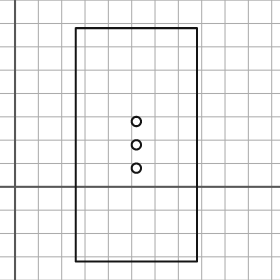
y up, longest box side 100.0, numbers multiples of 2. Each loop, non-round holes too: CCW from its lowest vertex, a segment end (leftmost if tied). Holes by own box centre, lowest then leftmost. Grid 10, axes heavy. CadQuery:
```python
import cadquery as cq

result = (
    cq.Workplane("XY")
    .moveTo(26.0, -32.0)
    .lineTo(78.0, -32.0)
    .lineTo(78.0, 68.0)
    .lineTo(26.0, 68.0)
    .close()
    .moveTo(52.0, 8.0)
    .circle(2.0)
    .moveTo(52.0, 18.0)
    .circle(2.0)
    .moveTo(52.0, 28.0)
    .circle(2.0)
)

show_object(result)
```